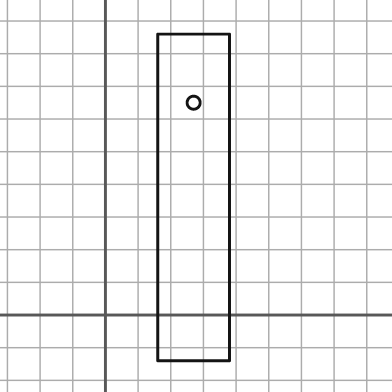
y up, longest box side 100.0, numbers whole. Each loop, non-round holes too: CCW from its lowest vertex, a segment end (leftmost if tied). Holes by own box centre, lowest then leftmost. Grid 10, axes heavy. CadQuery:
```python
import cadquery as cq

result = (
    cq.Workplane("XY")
    .moveTo(16.0, -14.0)
    .lineTo(38.0, -14.0)
    .lineTo(38.0, 86.0)
    .lineTo(16.0, 86.0)
    .close()
    .moveTo(27.0, 65.0)
    .circle(2.0)
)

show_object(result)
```